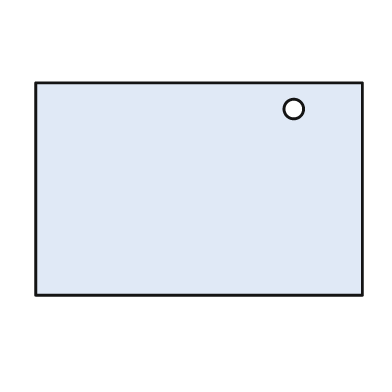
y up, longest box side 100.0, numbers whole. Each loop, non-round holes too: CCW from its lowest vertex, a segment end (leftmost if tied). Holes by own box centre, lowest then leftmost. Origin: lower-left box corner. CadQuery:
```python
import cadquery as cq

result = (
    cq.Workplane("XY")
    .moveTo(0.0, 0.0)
    .lineTo(100.0, 0.0)
    .lineTo(100.0, 65.0)
    .lineTo(0.0, 65.0)
    .close()
    .moveTo(79.0, 57.0)
    .circle(3.0)
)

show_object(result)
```